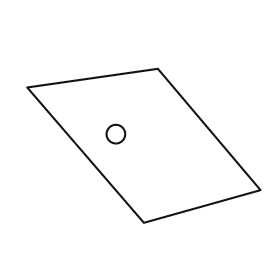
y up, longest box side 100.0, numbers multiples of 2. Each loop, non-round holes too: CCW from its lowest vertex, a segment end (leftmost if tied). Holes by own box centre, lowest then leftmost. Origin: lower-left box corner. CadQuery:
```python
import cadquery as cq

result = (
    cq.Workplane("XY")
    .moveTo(50.0, 0.0)
    .lineTo(100.0, 14.0)
    .lineTo(56.0, 66.0)
    .lineTo(0.0, 58.0)
    .close()
    .moveTo(38.0, 38.0)
    .circle(4.0)
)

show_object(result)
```